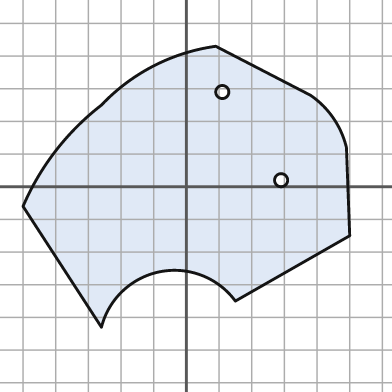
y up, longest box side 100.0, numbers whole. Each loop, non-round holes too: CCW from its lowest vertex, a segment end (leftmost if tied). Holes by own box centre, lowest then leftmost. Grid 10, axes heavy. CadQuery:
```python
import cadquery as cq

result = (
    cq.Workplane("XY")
    .moveTo(-26.0, -43.0)
    .threePointArc((-8.0, -26.0), (15.0, -35.0))
    .lineTo(50.0, -15.0)
    .lineTo(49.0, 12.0)
    .threePointArc((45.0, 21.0), (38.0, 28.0))
    .lineTo(9.0, 43.0)
    .threePointArc((-10.0, 37.0), (-26.0, 25.0))
    .threePointArc((-40.0, 11.0), (-50.0, -6.0))
    .close()
    .moveTo(29.0, 2.0)
    .circle(2.0)
    .moveTo(11.0, 29.0)
    .circle(2.0)
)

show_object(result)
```